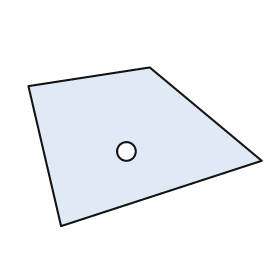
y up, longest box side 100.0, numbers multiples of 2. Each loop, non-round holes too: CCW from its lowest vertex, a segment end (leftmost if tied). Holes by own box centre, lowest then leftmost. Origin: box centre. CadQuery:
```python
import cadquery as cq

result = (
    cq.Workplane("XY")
    .moveTo(-36.0, -34.0)
    .lineTo(50.0, -6.0)
    .lineTo(2.0, 34.0)
    .lineTo(-50.0, 26.0)
    .close()
    .moveTo(-8.0, -2.0)
    .circle(4.0)
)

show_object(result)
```